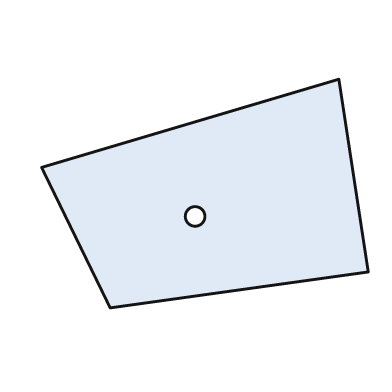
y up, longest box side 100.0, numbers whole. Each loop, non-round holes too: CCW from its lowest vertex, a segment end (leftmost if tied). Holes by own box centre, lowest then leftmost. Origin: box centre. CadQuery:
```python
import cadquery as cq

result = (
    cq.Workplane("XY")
    .moveTo(-29.0, -35.0)
    .lineTo(50.0, -24.0)
    .lineTo(41.0, 35.0)
    .lineTo(-50.0, 8.0)
    .close()
    .moveTo(-3.0, -7.0)
    .circle(3.0)
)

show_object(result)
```